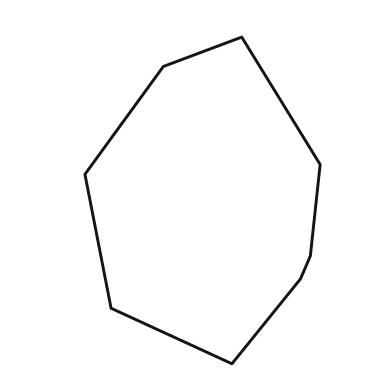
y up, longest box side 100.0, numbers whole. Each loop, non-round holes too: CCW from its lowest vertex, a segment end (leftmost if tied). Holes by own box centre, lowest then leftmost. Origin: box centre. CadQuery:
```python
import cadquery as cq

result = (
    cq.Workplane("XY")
    .moveTo(9.0, -50.0)
    .lineTo(30.0, -24.0)
    .lineTo(33.0, -17.0)
    .lineTo(36.0, 11.0)
    .lineTo(12.0, 50.0)
    .lineTo(-12.0, 41.0)
    .lineTo(-36.0, 8.0)
    .lineTo(-28.0, -33.0)
    .close()
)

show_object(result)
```